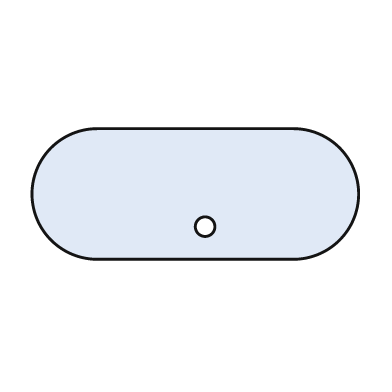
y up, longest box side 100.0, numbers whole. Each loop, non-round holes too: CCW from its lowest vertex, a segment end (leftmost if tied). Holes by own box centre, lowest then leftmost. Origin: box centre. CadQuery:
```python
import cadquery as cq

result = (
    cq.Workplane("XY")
    .moveTo(-30.0, -20.0)
    .lineTo(30.0, -20.0)
    .threePointArc((50.0, 0.0), (30.0, 20.0))
    .lineTo(-30.0, 20.0)
    .threePointArc((-50.0, 0.0), (-30.0, -20.0))
    .close()
    .moveTo(3.0, -10.0)
    .circle(3.0)
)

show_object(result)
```